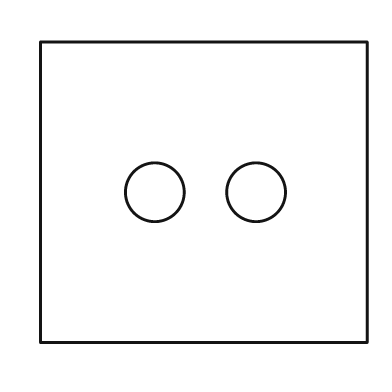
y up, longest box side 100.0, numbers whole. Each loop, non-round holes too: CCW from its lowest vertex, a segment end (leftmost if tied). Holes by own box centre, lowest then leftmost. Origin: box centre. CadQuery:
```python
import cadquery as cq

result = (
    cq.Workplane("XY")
    .moveTo(-50.0, -46.0)
    .lineTo(50.0, -46.0)
    .lineTo(50.0, 46.0)
    .lineTo(-50.0, 46.0)
    .close()
    .moveTo(-15.0, 0.0)
    .circle(9.0)
    .moveTo(16.0, 0.0)
    .circle(9.0)
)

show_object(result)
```